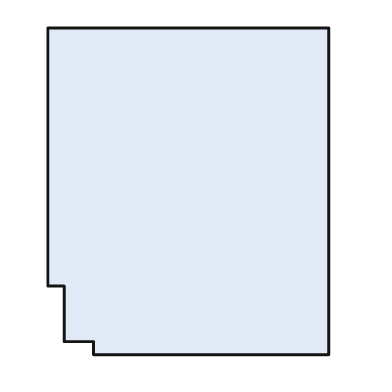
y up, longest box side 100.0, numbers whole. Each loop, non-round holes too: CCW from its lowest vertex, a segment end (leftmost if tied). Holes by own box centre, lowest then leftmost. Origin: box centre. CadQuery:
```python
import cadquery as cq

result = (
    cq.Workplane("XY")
    .moveTo(-29.0, -50.0)
    .lineTo(43.0, -50.0)
    .lineTo(43.0, 50.0)
    .lineTo(-43.0, 50.0)
    .lineTo(-43.0, -29.0)
    .lineTo(-38.0, -29.0)
    .lineTo(-38.0, -46.0)
    .lineTo(-29.0, -46.0)
    .close()
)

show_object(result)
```